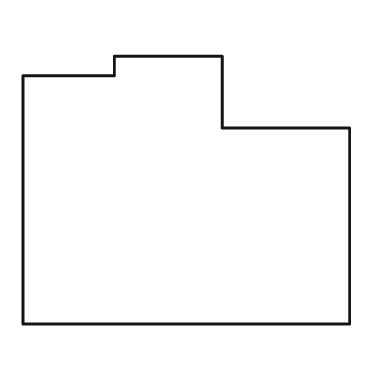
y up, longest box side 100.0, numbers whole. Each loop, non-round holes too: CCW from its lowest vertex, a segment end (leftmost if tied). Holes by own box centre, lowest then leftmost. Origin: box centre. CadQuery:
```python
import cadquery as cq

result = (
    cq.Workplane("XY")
    .moveTo(-50.0, -41.0)
    .lineTo(50.0, -41.0)
    .lineTo(50.0, 19.0)
    .lineTo(11.0, 19.0)
    .lineTo(11.0, 41.0)
    .lineTo(-22.0, 41.0)
    .lineTo(-22.0, 35.0)
    .lineTo(-50.0, 35.0)
    .close()
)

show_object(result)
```